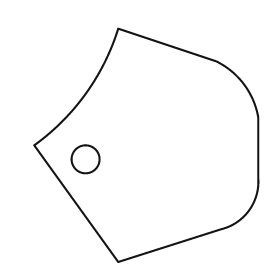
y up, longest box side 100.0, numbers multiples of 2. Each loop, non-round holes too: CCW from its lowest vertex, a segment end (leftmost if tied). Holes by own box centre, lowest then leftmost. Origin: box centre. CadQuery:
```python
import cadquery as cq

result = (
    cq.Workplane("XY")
    .moveTo(-12.0, -50.0)
    .lineTo(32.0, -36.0)
    .threePointArc((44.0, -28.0), (48.0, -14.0))
    .lineTo(48.0, 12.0)
    .threePointArc((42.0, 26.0), (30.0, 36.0))
    .lineTo(-12.0, 50.0)
    .threePointArc((-26.0, 22.0), (-48.0, 0.0))
    .close()
    .moveTo(-26.0, -6.0)
    .circle(6.0)
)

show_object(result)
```